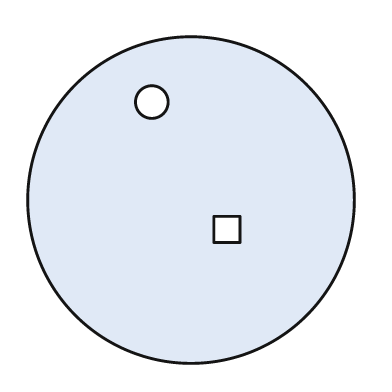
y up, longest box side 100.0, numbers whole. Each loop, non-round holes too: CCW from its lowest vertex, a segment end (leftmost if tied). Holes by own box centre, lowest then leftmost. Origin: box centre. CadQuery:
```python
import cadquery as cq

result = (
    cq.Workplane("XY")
    .moveTo(0.0, 0.0)
    .circle(50.0)
    .moveTo(7.0, -13.0)
    .lineTo(15.0, -13.0)
    .lineTo(15.0, -5.0)
    .lineTo(7.0, -5.0)
    .close()
    .moveTo(-12.0, 30.0)
    .circle(5.0)
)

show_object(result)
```